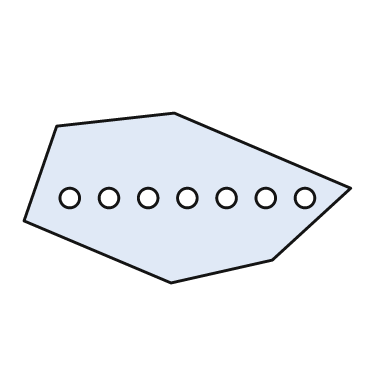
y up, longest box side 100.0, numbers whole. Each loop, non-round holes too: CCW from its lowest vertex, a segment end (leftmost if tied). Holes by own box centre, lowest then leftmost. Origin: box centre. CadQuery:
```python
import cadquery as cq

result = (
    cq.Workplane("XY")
    .moveTo(-5.0, -26.0)
    .lineTo(26.0, -19.0)
    .lineTo(50.0, 3.0)
    .lineTo(-4.0, 26.0)
    .lineTo(-40.0, 22.0)
    .lineTo(-50.0, -7.0)
    .close()
    .moveTo(-36.0, 0.0)
    .circle(3.0)
    .moveTo(-24.0, 0.0)
    .circle(3.0)
    .moveTo(-12.0, 0.0)
    .circle(3.0)
    .moveTo(0.0, 0.0)
    .circle(3.0)
    .moveTo(12.0, 0.0)
    .circle(3.0)
    .moveTo(24.0, 0.0)
    .circle(3.0)
    .moveTo(36.0, 0.0)
    .circle(3.0)
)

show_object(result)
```